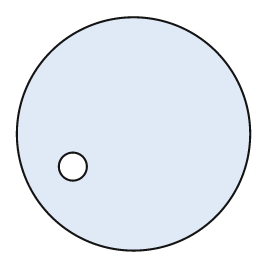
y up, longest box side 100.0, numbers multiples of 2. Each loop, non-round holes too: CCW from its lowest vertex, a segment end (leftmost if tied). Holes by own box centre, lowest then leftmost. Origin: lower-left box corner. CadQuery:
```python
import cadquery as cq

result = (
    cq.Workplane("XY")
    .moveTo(50.0, 50.0)
    .circle(50.0)
    .moveTo(24.0, 36.0)
    .circle(6.0)
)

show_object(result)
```